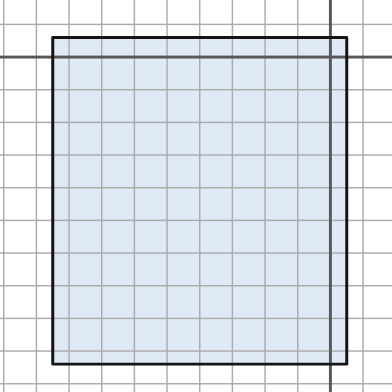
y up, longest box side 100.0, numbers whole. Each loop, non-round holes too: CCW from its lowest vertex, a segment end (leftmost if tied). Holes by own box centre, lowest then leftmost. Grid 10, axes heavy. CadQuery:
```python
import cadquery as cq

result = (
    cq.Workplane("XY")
    .moveTo(-85.0, -94.0)
    .lineTo(5.0, -94.0)
    .lineTo(5.0, 6.0)
    .lineTo(-85.0, 6.0)
    .close()
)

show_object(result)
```